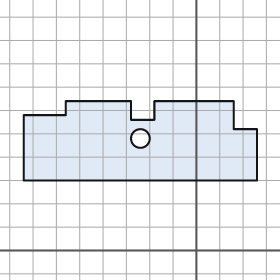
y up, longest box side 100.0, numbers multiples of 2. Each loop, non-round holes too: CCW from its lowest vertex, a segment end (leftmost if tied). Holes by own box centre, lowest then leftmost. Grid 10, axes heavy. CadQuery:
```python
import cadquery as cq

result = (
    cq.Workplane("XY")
    .moveTo(-74.0, 30.0)
    .lineTo(26.0, 30.0)
    .lineTo(26.0, 52.0)
    .lineTo(16.0, 52.0)
    .lineTo(16.0, 64.0)
    .lineTo(-18.0, 64.0)
    .lineTo(-18.0, 56.0)
    .lineTo(-28.0, 56.0)
    .lineTo(-28.0, 64.0)
    .lineTo(-56.0, 64.0)
    .lineTo(-56.0, 58.0)
    .lineTo(-74.0, 58.0)
    .close()
    .moveTo(-24.0, 48.0)
    .circle(4.0)
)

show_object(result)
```